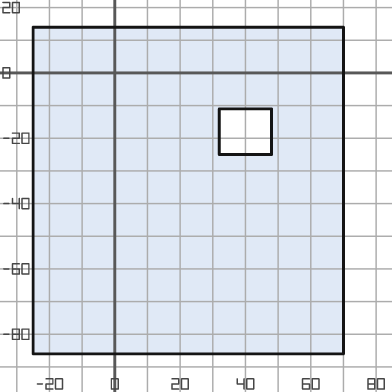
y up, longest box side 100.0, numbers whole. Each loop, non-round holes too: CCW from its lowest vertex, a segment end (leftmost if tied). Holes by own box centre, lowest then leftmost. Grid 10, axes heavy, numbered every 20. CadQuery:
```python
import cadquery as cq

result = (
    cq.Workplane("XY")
    .moveTo(-25.0, -86.0)
    .lineTo(70.0, -86.0)
    .lineTo(70.0, 14.0)
    .lineTo(-25.0, 14.0)
    .close()
    .moveTo(32.0, -25.0)
    .lineTo(48.0, -25.0)
    .lineTo(48.0, -11.0)
    .lineTo(32.0, -11.0)
    .close()
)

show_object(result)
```